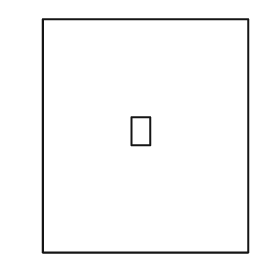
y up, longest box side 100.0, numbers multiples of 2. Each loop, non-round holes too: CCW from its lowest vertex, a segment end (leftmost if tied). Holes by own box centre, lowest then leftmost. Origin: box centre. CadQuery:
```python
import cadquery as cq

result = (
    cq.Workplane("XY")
    .moveTo(-44.0, -50.0)
    .lineTo(44.0, -50.0)
    .lineTo(44.0, 50.0)
    .lineTo(-44.0, 50.0)
    .close()
    .moveTo(-6.0, -4.0)
    .lineTo(2.0, -4.0)
    .lineTo(2.0, 8.0)
    .lineTo(-6.0, 8.0)
    .close()
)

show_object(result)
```